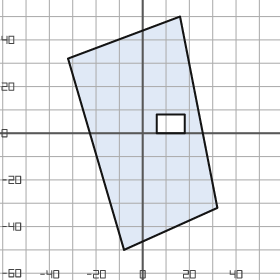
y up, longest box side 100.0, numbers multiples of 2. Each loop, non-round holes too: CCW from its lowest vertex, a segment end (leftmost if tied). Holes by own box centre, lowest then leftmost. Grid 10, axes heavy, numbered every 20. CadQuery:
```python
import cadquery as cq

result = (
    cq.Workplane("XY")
    .moveTo(-8.0, -50.0)
    .lineTo(32.0, -32.0)
    .lineTo(16.0, 50.0)
    .lineTo(-32.0, 32.0)
    .close()
    .moveTo(6.0, 0.0)
    .lineTo(18.0, 0.0)
    .lineTo(18.0, 8.0)
    .lineTo(6.0, 8.0)
    .close()
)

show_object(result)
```